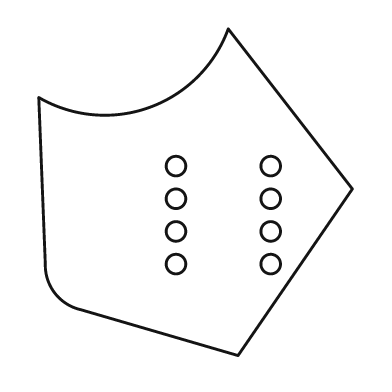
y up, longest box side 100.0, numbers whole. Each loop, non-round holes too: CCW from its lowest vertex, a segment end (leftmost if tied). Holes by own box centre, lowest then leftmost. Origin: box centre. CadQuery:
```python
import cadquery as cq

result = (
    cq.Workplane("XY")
    .moveTo(13.0, -50.0)
    .lineTo(48.0, 1.0)
    .lineTo(10.0, 50.0)
    .threePointArc((-14.0, 26.0), (-48.0, 29.0))
    .lineTo(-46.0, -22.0)
    .threePointArc((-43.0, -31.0), (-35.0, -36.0))
    .close()
    .moveTo(-6.0, -22.0)
    .circle(3.0)
    .moveTo(23.0, -22.0)
    .circle(3.0)
    .moveTo(-6.0, -12.0)
    .circle(3.0)
    .moveTo(23.0, -12.0)
    .circle(3.0)
    .moveTo(-6.0, -2.0)
    .circle(3.0)
    .moveTo(23.0, -2.0)
    .circle(3.0)
    .moveTo(-6.0, 8.0)
    .circle(3.0)
    .moveTo(23.0, 8.0)
    .circle(3.0)
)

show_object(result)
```